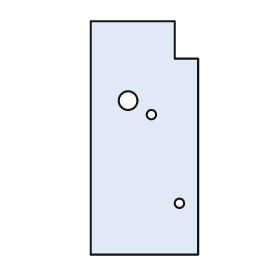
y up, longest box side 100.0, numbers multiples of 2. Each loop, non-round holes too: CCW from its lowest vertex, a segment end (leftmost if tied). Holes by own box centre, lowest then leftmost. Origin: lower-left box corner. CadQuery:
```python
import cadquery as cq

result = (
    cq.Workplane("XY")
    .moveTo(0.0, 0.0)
    .lineTo(46.0, 0.0)
    .lineTo(46.0, 84.0)
    .lineTo(36.0, 84.0)
    .lineTo(36.0, 100.0)
    .lineTo(0.0, 100.0)
    .close()
    .moveTo(38.0, 22.0)
    .circle(2.0)
    .moveTo(26.0, 60.0)
    .circle(2.0)
    .moveTo(16.0, 66.0)
    .circle(4.0)
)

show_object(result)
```